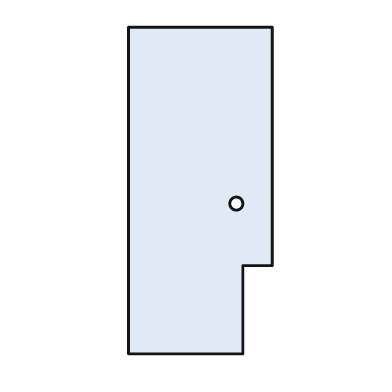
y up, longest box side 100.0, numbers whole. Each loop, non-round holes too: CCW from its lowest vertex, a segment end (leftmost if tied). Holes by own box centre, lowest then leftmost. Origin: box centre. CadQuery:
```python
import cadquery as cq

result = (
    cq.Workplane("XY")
    .moveTo(-22.0, -50.0)
    .lineTo(13.0, -50.0)
    .lineTo(13.0, -23.0)
    .lineTo(22.0, -23.0)
    .lineTo(22.0, 50.0)
    .lineTo(-22.0, 50.0)
    .close()
    .moveTo(11.0, -4.0)
    .circle(2.0)
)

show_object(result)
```